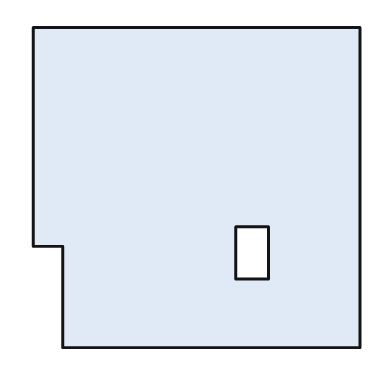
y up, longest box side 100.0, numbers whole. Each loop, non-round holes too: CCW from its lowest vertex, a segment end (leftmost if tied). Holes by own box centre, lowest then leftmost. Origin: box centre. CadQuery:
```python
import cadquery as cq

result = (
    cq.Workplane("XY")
    .moveTo(-41.0, -49.0)
    .lineTo(50.0, -49.0)
    .lineTo(50.0, 49.0)
    .lineTo(-50.0, 49.0)
    .lineTo(-50.0, -18.0)
    .lineTo(-41.0, -18.0)
    .close()
    .moveTo(12.0, -28.0)
    .lineTo(22.0, -28.0)
    .lineTo(22.0, -12.0)
    .lineTo(12.0, -12.0)
    .close()
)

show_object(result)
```